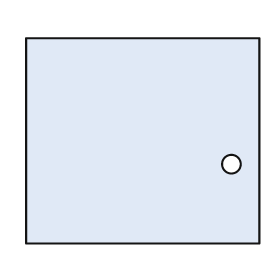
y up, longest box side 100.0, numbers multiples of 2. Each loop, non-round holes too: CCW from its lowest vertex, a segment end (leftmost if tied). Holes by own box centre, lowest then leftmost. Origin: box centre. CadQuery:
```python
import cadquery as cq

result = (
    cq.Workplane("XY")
    .moveTo(-50.0, -44.0)
    .lineTo(50.0, -44.0)
    .lineTo(50.0, 44.0)
    .lineTo(-50.0, 44.0)
    .close()
    .moveTo(38.0, -10.0)
    .circle(4.0)
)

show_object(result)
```